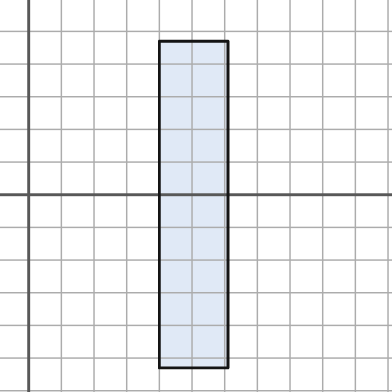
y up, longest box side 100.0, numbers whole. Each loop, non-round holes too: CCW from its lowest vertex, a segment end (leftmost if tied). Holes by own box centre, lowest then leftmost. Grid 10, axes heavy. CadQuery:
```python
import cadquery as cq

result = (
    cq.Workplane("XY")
    .moveTo(40.0, -53.0)
    .lineTo(61.0, -53.0)
    .lineTo(61.0, 47.0)
    .lineTo(40.0, 47.0)
    .close()
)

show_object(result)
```